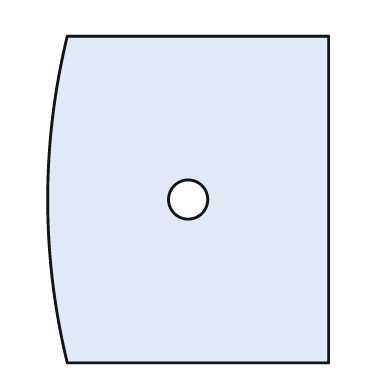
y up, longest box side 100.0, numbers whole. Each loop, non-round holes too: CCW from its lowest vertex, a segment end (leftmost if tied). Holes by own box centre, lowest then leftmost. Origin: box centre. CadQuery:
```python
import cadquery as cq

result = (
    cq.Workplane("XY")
    .moveTo(-37.0, -50.0)
    .lineTo(43.0, -50.0)
    .lineTo(43.0, 50.0)
    .lineTo(-37.0, 50.0)
    .threePointArc((-43.0, 0.0), (-37.0, -50.0))
    .close()
    .moveTo(0.0, 0.0)
    .circle(6.0)
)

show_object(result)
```